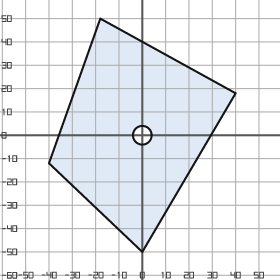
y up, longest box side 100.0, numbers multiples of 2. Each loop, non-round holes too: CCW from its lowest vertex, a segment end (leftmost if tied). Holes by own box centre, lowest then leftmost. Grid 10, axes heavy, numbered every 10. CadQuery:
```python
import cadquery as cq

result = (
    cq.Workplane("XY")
    .moveTo(0.0, -50.0)
    .lineTo(40.0, 18.0)
    .lineTo(-18.0, 50.0)
    .lineTo(-40.0, -12.0)
    .close()
    .moveTo(0.0, 0.0)
    .circle(4.0)
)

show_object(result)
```